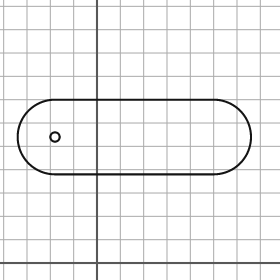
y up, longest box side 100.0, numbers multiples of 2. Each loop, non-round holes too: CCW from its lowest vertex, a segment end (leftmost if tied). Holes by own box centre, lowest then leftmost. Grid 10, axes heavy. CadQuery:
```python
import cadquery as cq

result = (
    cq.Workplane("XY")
    .moveTo(-18.0, 38.0)
    .lineTo(50.0, 38.0)
    .threePointArc((66.0, 54.0), (50.0, 70.0))
    .lineTo(-18.0, 70.0)
    .threePointArc((-34.0, 54.0), (-18.0, 38.0))
    .close()
    .moveTo(-18.0, 54.0)
    .circle(2.0)
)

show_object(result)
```